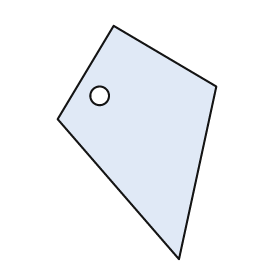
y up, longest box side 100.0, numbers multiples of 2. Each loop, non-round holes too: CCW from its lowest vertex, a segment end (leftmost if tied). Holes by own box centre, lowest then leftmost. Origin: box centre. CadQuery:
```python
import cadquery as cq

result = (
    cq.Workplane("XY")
    .moveTo(18.0, -50.0)
    .lineTo(34.0, 24.0)
    .lineTo(-10.0, 50.0)
    .lineTo(-34.0, 10.0)
    .close()
    .moveTo(-16.0, 20.0)
    .circle(4.0)
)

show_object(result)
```